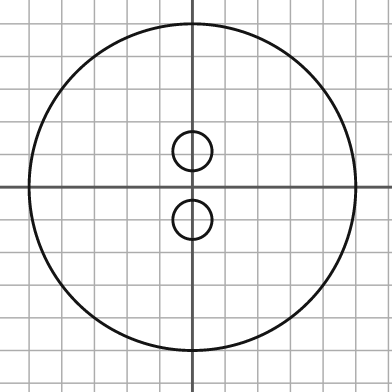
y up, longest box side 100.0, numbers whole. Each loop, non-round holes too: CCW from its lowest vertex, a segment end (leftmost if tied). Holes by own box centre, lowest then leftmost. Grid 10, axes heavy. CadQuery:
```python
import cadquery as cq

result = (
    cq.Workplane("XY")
    .moveTo(0.0, 0.0)
    .circle(50.0)
    .moveTo(0.0, -10.0)
    .circle(6.0)
    .moveTo(0.0, 11.0)
    .circle(6.0)
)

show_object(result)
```